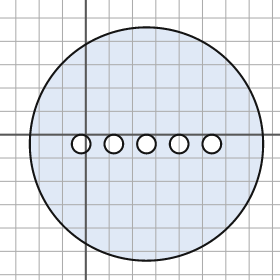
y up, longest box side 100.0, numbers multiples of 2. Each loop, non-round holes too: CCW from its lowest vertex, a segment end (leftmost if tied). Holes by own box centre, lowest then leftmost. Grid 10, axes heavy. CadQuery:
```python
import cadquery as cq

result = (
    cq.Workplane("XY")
    .moveTo(26.0, -4.0)
    .circle(50.0)
    .moveTo(-2.0, -4.0)
    .circle(4.0)
    .moveTo(12.0, -4.0)
    .circle(4.0)
    .moveTo(26.0, -4.0)
    .circle(4.0)
    .moveTo(40.0, -4.0)
    .circle(4.0)
    .moveTo(54.0, -4.0)
    .circle(4.0)
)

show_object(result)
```